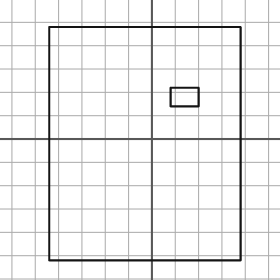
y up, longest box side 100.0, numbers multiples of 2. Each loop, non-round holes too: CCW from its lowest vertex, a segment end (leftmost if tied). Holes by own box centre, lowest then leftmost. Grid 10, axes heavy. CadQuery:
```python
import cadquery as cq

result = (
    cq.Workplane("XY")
    .moveTo(-44.0, -52.0)
    .lineTo(38.0, -52.0)
    .lineTo(38.0, 48.0)
    .lineTo(-44.0, 48.0)
    .close()
    .moveTo(8.0, 14.0)
    .lineTo(20.0, 14.0)
    .lineTo(20.0, 22.0)
    .lineTo(8.0, 22.0)
    .close()
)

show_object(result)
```